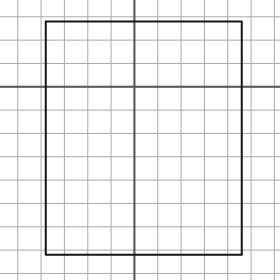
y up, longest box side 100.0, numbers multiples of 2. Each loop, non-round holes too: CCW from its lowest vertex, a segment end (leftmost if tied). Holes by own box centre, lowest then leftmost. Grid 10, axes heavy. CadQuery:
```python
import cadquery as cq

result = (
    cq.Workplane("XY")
    .moveTo(-38.0, -72.0)
    .lineTo(46.0, -72.0)
    .lineTo(46.0, 28.0)
    .lineTo(-38.0, 28.0)
    .close()
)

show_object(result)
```